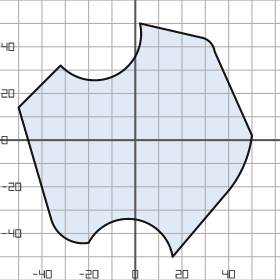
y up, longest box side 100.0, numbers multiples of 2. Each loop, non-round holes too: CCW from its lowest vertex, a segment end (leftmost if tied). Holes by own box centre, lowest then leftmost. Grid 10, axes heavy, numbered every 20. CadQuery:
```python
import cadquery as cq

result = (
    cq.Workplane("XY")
    .moveTo(16.0, -50.0)
    .lineTo(38.0, -24.0)
    .threePointArc((46.0, -12.0), (50.0, 2.0))
    .lineTo(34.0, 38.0)
    .threePointArc((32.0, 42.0), (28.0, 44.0))
    .lineTo(2.0, 50.0)
    .threePointArc((-8.0, 28.0), (-32.0, 32.0))
    .lineTo(-50.0, 14.0)
    .lineTo(-36.0, -34.0)
    .threePointArc((-30.0, -42.0), (-20.0, -44.0))
    .threePointArc((0.0, -34.0), (16.0, -50.0))
    .close()
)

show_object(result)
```